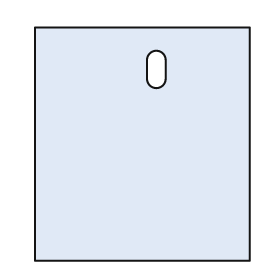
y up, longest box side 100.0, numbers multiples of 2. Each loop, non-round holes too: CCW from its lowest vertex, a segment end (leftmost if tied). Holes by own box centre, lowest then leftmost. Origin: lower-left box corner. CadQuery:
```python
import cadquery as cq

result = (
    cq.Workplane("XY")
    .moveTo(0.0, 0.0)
    .lineTo(92.0, 0.0)
    .lineTo(92.0, 100.0)
    .lineTo(0.0, 100.0)
    .close()
    .moveTo(48.0, 78.0)
    .threePointArc((52.0, 74.0), (56.0, 78.0))
    .lineTo(56.0, 86.0)
    .threePointArc((52.0, 90.0), (48.0, 86.0))
    .close()
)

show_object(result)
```